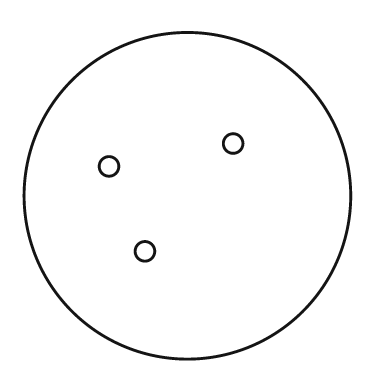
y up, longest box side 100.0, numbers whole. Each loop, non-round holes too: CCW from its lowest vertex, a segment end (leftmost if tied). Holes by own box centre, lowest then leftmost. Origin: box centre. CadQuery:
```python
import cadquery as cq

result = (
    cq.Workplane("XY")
    .moveTo(0.0, 0.0)
    .circle(50.0)
    .moveTo(-13.0, -17.0)
    .circle(3.0)
    .moveTo(-24.0, 9.0)
    .circle(3.0)
    .moveTo(14.0, 16.0)
    .circle(3.0)
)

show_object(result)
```